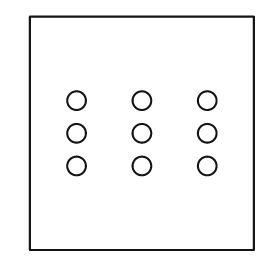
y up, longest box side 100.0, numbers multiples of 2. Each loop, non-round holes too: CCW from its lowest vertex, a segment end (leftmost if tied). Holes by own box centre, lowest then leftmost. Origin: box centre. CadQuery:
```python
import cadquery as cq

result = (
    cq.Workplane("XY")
    .moveTo(-48.0, -50.0)
    .lineTo(48.0, -50.0)
    .lineTo(48.0, 50.0)
    .lineTo(-48.0, 50.0)
    .close()
    .moveTo(-28.0, -14.0)
    .circle(4.0)
    .moveTo(0.0, -14.0)
    .circle(4.0)
    .moveTo(28.0, -14.0)
    .circle(4.0)
    .moveTo(-28.0, 0.0)
    .circle(4.0)
    .moveTo(0.0, 0.0)
    .circle(4.0)
    .moveTo(28.0, 0.0)
    .circle(4.0)
    .moveTo(-28.0, 14.0)
    .circle(4.0)
    .moveTo(0.0, 14.0)
    .circle(4.0)
    .moveTo(28.0, 14.0)
    .circle(4.0)
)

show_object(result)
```